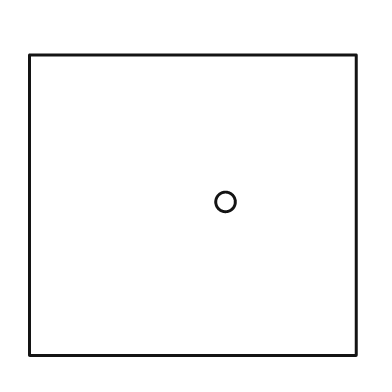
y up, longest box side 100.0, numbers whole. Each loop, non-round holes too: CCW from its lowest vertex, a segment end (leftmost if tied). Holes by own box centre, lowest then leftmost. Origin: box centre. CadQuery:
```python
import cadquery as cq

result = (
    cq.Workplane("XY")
    .moveTo(-50.0, -46.0)
    .lineTo(50.0, -46.0)
    .lineTo(50.0, 46.0)
    .lineTo(-50.0, 46.0)
    .close()
    .moveTo(10.0, 1.0)
    .circle(3.0)
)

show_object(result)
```